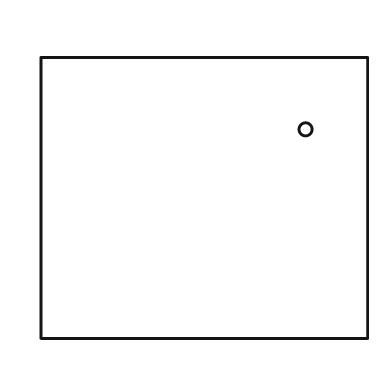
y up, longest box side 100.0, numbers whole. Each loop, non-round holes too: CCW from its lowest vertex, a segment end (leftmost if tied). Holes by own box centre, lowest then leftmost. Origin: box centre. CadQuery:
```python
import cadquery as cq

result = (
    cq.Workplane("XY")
    .moveTo(-50.0, -43.0)
    .lineTo(50.0, -43.0)
    .lineTo(50.0, 43.0)
    .lineTo(-50.0, 43.0)
    .close()
    .moveTo(31.0, 21.0)
    .circle(2.0)
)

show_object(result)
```